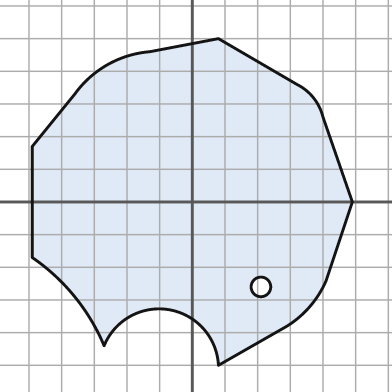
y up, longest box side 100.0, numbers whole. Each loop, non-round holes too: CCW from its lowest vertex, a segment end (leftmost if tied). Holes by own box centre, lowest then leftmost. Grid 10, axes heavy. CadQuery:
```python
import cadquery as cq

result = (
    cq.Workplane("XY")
    .moveTo(8.0, -50.0)
    .lineTo(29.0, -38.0)
    .threePointArc((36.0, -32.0), (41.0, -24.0))
    .lineTo(49.0, 0.0)
    .lineTo(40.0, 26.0)
    .threePointArc((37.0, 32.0), (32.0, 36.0))
    .lineTo(8.0, 50.0)
    .lineTo(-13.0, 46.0)
    .threePointArc((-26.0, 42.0), (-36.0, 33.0))
    .lineTo(-49.0, 17.0)
    .lineTo(-49.0, -17.0)
    .threePointArc((-36.0, -29.0), (-27.0, -44.0))
    .threePointArc((-7.0, -33.0), (8.0, -50.0))
    .close()
    .moveTo(21.0, -26.0)
    .circle(3.0)
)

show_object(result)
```